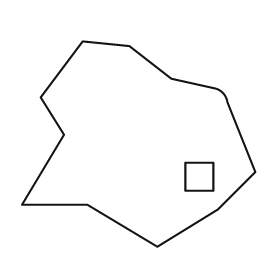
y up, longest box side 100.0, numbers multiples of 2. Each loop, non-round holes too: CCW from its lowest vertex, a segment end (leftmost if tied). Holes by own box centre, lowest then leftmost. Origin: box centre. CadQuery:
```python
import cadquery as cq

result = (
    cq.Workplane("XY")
    .moveTo(8.0, -44.0)
    .lineTo(34.0, -28.0)
    .lineTo(50.0, -12.0)
    .lineTo(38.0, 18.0)
    .threePointArc((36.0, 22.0), (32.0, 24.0))
    .lineTo(14.0, 28.0)
    .lineTo(-4.0, 42.0)
    .lineTo(-24.0, 44.0)
    .lineTo(-42.0, 20.0)
    .lineTo(-32.0, 4.0)
    .lineTo(-50.0, -26.0)
    .lineTo(-22.0, -26.0)
    .close()
    .moveTo(20.0, -20.0)
    .lineTo(32.0, -20.0)
    .lineTo(32.0, -8.0)
    .lineTo(20.0, -8.0)
    .close()
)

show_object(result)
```